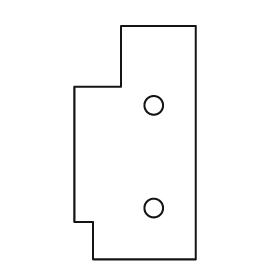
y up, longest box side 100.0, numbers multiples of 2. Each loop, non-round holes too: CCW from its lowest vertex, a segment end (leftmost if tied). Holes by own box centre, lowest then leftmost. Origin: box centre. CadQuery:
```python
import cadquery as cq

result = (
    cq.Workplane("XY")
    .moveTo(-18.0, -50.0)
    .lineTo(26.0, -50.0)
    .lineTo(26.0, 50.0)
    .lineTo(-6.0, 50.0)
    .lineTo(-6.0, 24.0)
    .lineTo(-26.0, 24.0)
    .lineTo(-26.0, -34.0)
    .lineTo(-18.0, -34.0)
    .close()
    .moveTo(8.0, -28.0)
    .circle(4.0)
    .moveTo(8.0, 16.0)
    .circle(4.0)
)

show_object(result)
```